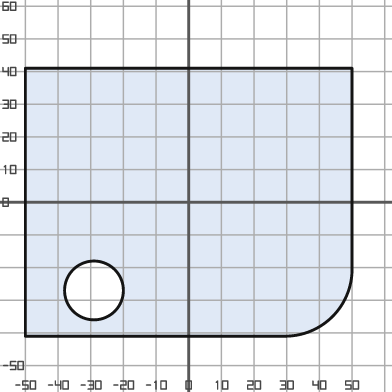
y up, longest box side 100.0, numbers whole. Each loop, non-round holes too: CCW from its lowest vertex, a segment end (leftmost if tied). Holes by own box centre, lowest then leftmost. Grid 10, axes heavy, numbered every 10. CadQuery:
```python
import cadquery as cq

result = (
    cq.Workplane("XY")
    .moveTo(-50.0, -41.0)
    .lineTo(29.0, -41.0)
    .threePointArc((44.0, -35.0), (50.0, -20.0))
    .lineTo(50.0, 41.0)
    .lineTo(-50.0, 41.0)
    .close()
    .moveTo(-29.0, -27.0)
    .circle(9.0)
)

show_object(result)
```